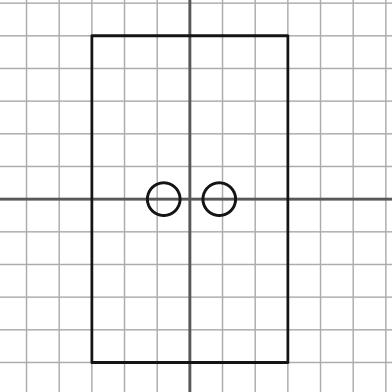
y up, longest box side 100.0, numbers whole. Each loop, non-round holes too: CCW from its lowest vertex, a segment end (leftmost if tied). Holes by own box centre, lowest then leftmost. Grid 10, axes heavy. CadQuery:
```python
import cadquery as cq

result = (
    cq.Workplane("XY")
    .moveTo(-30.0, -50.0)
    .lineTo(30.0, -50.0)
    .lineTo(30.0, 50.0)
    .lineTo(-30.0, 50.0)
    .close()
    .moveTo(-8.0, 0.0)
    .circle(5.0)
    .moveTo(9.0, 0.0)
    .circle(5.0)
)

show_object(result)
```